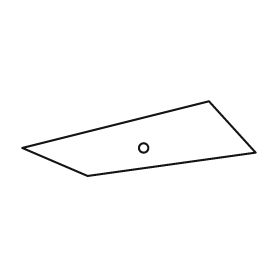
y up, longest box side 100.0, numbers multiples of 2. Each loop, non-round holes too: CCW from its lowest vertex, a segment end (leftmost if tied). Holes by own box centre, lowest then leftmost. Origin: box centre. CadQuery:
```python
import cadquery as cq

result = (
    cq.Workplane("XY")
    .moveTo(-22.0, -16.0)
    .lineTo(50.0, -6.0)
    .lineTo(30.0, 16.0)
    .lineTo(-50.0, -4.0)
    .close()
    .moveTo(2.0, -4.0)
    .circle(2.0)
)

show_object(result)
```